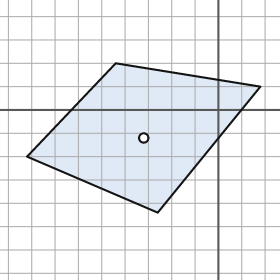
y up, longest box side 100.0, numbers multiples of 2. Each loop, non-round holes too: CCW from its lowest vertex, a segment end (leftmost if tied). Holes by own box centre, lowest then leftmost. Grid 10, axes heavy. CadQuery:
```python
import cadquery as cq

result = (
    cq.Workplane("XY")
    .moveTo(-26.0, -44.0)
    .lineTo(18.0, 10.0)
    .lineTo(-44.0, 20.0)
    .lineTo(-82.0, -20.0)
    .close()
    .moveTo(-32.0, -12.0)
    .circle(2.0)
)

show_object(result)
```